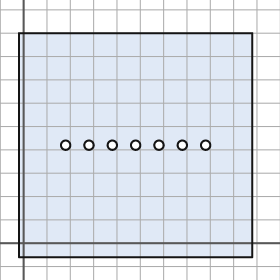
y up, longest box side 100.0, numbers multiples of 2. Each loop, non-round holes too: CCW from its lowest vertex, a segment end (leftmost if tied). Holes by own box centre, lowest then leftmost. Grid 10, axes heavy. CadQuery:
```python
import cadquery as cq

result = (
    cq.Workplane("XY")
    .moveTo(-2.0, -6.0)
    .lineTo(98.0, -6.0)
    .lineTo(98.0, 90.0)
    .lineTo(-2.0, 90.0)
    .close()
    .moveTo(18.0, 42.0)
    .circle(2.0)
    .moveTo(28.0, 42.0)
    .circle(2.0)
    .moveTo(38.0, 42.0)
    .circle(2.0)
    .moveTo(48.0, 42.0)
    .circle(2.0)
    .moveTo(58.0, 42.0)
    .circle(2.0)
    .moveTo(68.0, 42.0)
    .circle(2.0)
    .moveTo(78.0, 42.0)
    .circle(2.0)
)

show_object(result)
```